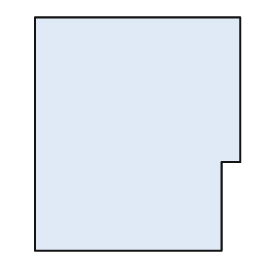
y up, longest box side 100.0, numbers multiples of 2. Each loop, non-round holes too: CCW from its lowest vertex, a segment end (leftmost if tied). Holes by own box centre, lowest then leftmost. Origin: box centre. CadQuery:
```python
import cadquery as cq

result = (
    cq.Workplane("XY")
    .moveTo(-44.0, -50.0)
    .lineTo(36.0, -50.0)
    .lineTo(36.0, -12.0)
    .lineTo(44.0, -12.0)
    .lineTo(44.0, 50.0)
    .lineTo(-44.0, 50.0)
    .close()
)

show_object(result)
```